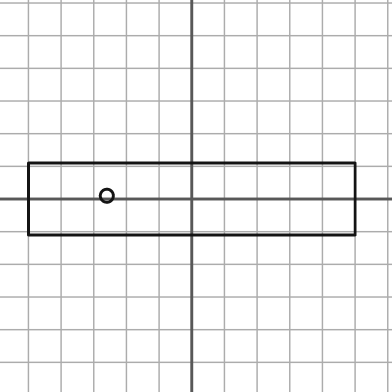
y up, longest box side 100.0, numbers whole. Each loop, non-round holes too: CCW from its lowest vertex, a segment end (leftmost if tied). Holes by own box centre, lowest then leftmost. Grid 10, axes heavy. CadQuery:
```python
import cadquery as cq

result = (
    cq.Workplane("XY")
    .moveTo(-50.0, -11.0)
    .lineTo(50.0, -11.0)
    .lineTo(50.0, 11.0)
    .lineTo(-50.0, 11.0)
    .close()
    .moveTo(-26.0, 1.0)
    .circle(2.0)
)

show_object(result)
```